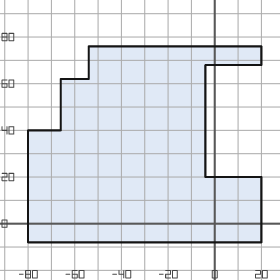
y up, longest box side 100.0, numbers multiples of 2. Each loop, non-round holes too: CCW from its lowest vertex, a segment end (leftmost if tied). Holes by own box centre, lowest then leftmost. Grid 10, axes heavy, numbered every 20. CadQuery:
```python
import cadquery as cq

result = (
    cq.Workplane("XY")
    .moveTo(-80.0, -8.0)
    .lineTo(20.0, -8.0)
    .lineTo(20.0, 20.0)
    .lineTo(-4.0, 20.0)
    .lineTo(-4.0, 68.0)
    .lineTo(20.0, 68.0)
    .lineTo(20.0, 76.0)
    .lineTo(-54.0, 76.0)
    .lineTo(-54.0, 62.0)
    .lineTo(-66.0, 62.0)
    .lineTo(-66.0, 40.0)
    .lineTo(-80.0, 40.0)
    .close()
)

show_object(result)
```